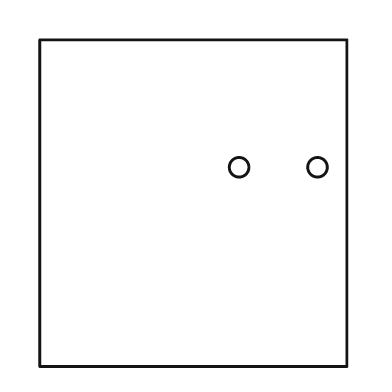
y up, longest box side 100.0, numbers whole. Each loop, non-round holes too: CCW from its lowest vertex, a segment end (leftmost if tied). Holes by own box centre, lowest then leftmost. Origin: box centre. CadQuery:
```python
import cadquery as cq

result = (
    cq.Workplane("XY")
    .moveTo(-47.0, -50.0)
    .lineTo(47.0, -50.0)
    .lineTo(47.0, 50.0)
    .lineTo(-47.0, 50.0)
    .close()
    .moveTo(14.0, 11.0)
    .circle(3.0)
    .moveTo(38.0, 11.0)
    .circle(3.0)
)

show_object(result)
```